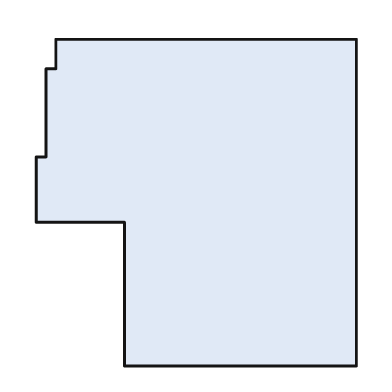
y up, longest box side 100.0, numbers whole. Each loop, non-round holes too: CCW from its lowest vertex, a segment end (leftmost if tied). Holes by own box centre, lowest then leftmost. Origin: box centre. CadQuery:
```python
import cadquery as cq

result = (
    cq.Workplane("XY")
    .moveTo(-22.0, -50.0)
    .lineTo(49.0, -50.0)
    .lineTo(49.0, 50.0)
    .lineTo(-43.0, 50.0)
    .lineTo(-43.0, 41.0)
    .lineTo(-46.0, 41.0)
    .lineTo(-46.0, 14.0)
    .lineTo(-49.0, 14.0)
    .lineTo(-49.0, -6.0)
    .lineTo(-22.0, -6.0)
    .close()
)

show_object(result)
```